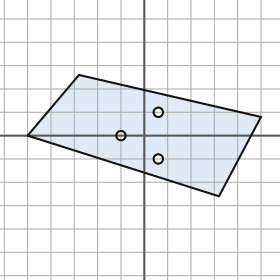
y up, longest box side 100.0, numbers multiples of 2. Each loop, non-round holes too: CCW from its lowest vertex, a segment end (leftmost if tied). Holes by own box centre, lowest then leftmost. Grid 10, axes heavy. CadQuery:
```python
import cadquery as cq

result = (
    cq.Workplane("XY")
    .moveTo(32.0, -26.0)
    .lineTo(50.0, 8.0)
    .lineTo(-28.0, 26.0)
    .lineTo(-50.0, 0.0)
    .close()
    .moveTo(6.0, -10.0)
    .circle(2.0)
    .moveTo(-10.0, 0.0)
    .circle(2.0)
    .moveTo(6.0, 10.0)
    .circle(2.0)
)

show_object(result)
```